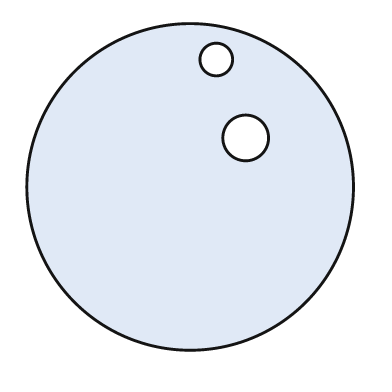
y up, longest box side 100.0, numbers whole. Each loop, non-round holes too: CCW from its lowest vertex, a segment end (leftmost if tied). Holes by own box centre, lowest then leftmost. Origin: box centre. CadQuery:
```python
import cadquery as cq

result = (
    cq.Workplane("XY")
    .moveTo(0.0, 0.0)
    .circle(50.0)
    .moveTo(17.0, 15.0)
    .circle(7.0)
    .moveTo(8.0, 39.0)
    .circle(5.0)
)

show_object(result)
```